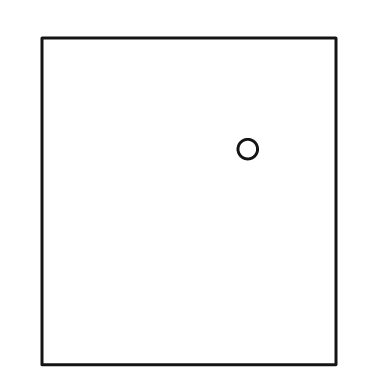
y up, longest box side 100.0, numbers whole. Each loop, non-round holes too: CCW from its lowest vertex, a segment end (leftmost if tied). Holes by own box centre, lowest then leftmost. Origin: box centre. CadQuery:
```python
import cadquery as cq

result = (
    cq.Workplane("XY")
    .moveTo(-45.0, -50.0)
    .lineTo(45.0, -50.0)
    .lineTo(45.0, 50.0)
    .lineTo(-45.0, 50.0)
    .close()
    .moveTo(18.0, 16.0)
    .circle(3.0)
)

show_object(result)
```